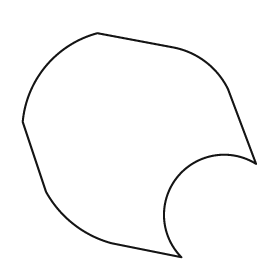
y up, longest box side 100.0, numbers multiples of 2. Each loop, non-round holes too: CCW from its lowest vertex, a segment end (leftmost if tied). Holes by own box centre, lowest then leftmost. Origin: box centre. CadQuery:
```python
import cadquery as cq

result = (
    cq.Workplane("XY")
    .moveTo(18.0, -48.0)
    .threePointArc((16.0, -14.0), (50.0, -8.0))
    .lineTo(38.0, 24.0)
    .threePointArc((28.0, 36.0), (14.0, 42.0))
    .lineTo(-18.0, 48.0)
    .threePointArc((-40.0, 34.0), (-50.0, 10.0))
    .lineTo(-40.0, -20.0)
    .threePointArc((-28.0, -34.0), (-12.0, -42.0))
    .close()
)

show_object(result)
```